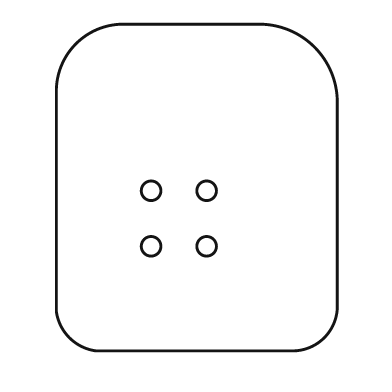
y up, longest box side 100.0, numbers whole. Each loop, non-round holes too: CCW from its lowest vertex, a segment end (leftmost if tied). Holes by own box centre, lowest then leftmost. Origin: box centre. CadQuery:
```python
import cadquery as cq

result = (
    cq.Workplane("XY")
    .moveTo(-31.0, -50.0)
    .lineTo(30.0, -50.0)
    .threePointArc((39.0, -46.0), (43.0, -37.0))
    .lineTo(43.0, 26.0)
    .threePointArc((36.0, 43.0), (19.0, 50.0))
    .lineTo(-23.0, 50.0)
    .threePointArc((-37.0, 44.0), (-43.0, 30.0))
    .lineTo(-43.0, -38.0)
    .threePointArc((-39.0, -46.0), (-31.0, -50.0))
    .close()
    .moveTo(-14.0, -18.0)
    .circle(3.0)
    .moveTo(3.0, -18.0)
    .circle(3.0)
    .moveTo(-14.0, -1.0)
    .circle(3.0)
    .moveTo(3.0, -1.0)
    .circle(3.0)
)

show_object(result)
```